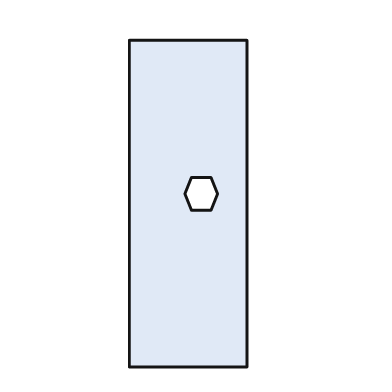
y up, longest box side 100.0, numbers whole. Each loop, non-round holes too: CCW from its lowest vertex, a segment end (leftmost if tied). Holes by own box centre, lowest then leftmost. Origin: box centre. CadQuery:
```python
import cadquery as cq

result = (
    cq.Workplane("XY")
    .moveTo(-18.0, -50.0)
    .lineTo(18.0, -50.0)
    .lineTo(18.0, 50.0)
    .lineTo(-18.0, 50.0)
    .close()
    .moveTo(1.0, -2.0)
    .lineTo(7.0, -2.0)
    .lineTo(9.0, 3.0)
    .lineTo(7.0, 8.0)
    .lineTo(1.0, 8.0)
    .lineTo(-1.0, 3.0)
    .close()
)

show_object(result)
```